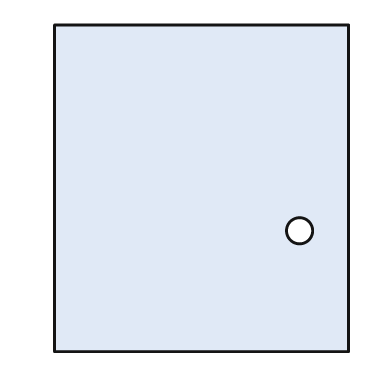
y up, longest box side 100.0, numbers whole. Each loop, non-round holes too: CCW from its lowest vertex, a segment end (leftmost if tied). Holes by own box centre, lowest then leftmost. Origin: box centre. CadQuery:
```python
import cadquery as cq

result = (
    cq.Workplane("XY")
    .moveTo(-45.0, -50.0)
    .lineTo(45.0, -50.0)
    .lineTo(45.0, 50.0)
    .lineTo(-45.0, 50.0)
    .close()
    .moveTo(30.0, -13.0)
    .circle(4.0)
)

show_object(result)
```